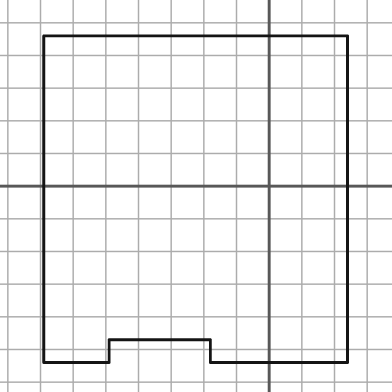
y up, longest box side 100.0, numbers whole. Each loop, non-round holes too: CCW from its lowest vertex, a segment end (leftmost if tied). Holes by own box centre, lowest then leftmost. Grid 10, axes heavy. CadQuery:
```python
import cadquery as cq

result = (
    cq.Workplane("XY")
    .moveTo(-69.0, -54.0)
    .lineTo(-49.0, -54.0)
    .lineTo(-49.0, -47.0)
    .lineTo(-18.0, -47.0)
    .lineTo(-18.0, -54.0)
    .lineTo(24.0, -54.0)
    .lineTo(24.0, 46.0)
    .lineTo(-69.0, 46.0)
    .close()
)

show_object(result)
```